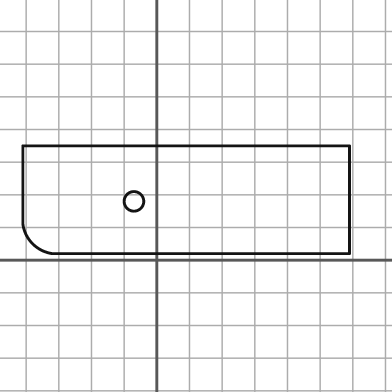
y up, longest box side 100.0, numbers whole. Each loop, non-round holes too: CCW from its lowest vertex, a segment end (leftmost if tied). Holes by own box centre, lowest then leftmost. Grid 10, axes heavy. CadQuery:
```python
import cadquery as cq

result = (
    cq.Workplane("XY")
    .moveTo(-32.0, 2.0)
    .lineTo(59.0, 2.0)
    .lineTo(59.0, 35.0)
    .lineTo(-41.0, 35.0)
    .lineTo(-41.0, 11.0)
    .threePointArc((-38.0, 5.0), (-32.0, 2.0))
    .close()
    .moveTo(-7.0, 18.0)
    .circle(3.0)
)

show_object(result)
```